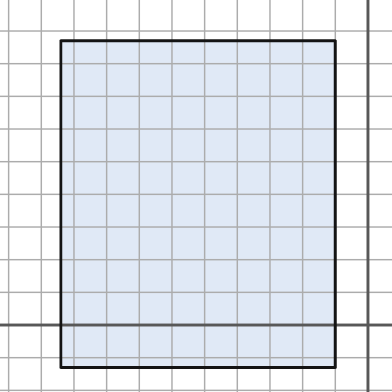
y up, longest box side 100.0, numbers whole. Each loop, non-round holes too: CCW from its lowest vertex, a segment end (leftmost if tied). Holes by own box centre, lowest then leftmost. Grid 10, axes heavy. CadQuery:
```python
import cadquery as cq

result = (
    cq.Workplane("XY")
    .moveTo(-94.0, -13.0)
    .lineTo(-10.0, -13.0)
    .lineTo(-10.0, 87.0)
    .lineTo(-94.0, 87.0)
    .close()
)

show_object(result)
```